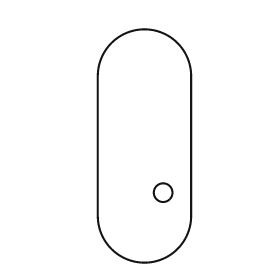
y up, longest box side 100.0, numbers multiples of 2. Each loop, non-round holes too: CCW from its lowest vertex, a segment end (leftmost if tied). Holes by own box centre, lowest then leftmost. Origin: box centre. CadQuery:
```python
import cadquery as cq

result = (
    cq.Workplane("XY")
    .moveTo(-20.0, -30.0)
    .threePointArc((0.0, -50.0), (20.0, -30.0))
    .lineTo(20.0, 30.0)
    .threePointArc((0.0, 50.0), (-20.0, 30.0))
    .close()
    .moveTo(8.0, -20.0)
    .circle(4.0)
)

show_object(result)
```